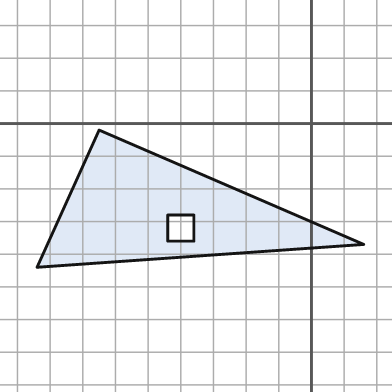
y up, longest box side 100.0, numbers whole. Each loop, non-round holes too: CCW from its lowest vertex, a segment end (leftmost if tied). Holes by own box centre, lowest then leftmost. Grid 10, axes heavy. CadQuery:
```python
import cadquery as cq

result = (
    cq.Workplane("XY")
    .moveTo(-84.0, -44.0)
    .lineTo(16.0, -37.0)
    .lineTo(-65.0, -2.0)
    .close()
    .moveTo(-44.0, -36.0)
    .lineTo(-36.0, -36.0)
    .lineTo(-36.0, -28.0)
    .lineTo(-44.0, -28.0)
    .close()
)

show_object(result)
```